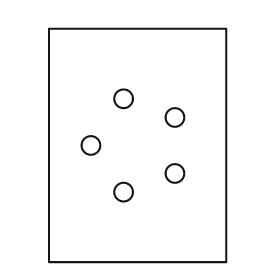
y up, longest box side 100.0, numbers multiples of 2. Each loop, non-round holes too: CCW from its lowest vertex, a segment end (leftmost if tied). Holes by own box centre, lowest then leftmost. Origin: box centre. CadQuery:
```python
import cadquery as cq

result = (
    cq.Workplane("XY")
    .moveTo(-38.0, -50.0)
    .lineTo(38.0, -50.0)
    .lineTo(38.0, 50.0)
    .lineTo(-38.0, 50.0)
    .close()
    .moveTo(-6.0, -20.0)
    .circle(4.0)
    .moveTo(16.0, -12.0)
    .circle(4.0)
    .moveTo(-20.0, 0.0)
    .circle(4.0)
    .moveTo(16.0, 12.0)
    .circle(4.0)
    .moveTo(-6.0, 20.0)
    .circle(4.0)
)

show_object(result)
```